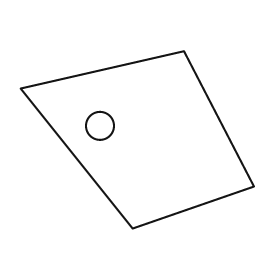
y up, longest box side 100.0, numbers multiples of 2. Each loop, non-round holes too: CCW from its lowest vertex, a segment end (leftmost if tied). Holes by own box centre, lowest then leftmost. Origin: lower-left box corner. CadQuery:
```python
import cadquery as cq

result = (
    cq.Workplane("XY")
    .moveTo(48.0, 0.0)
    .lineTo(100.0, 18.0)
    .lineTo(70.0, 76.0)
    .lineTo(0.0, 60.0)
    .close()
    .moveTo(34.0, 44.0)
    .circle(6.0)
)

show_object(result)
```